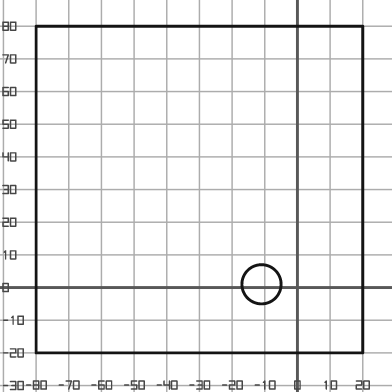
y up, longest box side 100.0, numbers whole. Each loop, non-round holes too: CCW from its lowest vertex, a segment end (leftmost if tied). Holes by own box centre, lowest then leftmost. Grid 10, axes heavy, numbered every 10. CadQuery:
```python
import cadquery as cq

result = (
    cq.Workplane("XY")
    .moveTo(-80.0, -20.0)
    .lineTo(20.0, -20.0)
    .lineTo(20.0, 80.0)
    .lineTo(-80.0, 80.0)
    .close()
    .moveTo(-11.0, 1.0)
    .circle(6.0)
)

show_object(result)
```